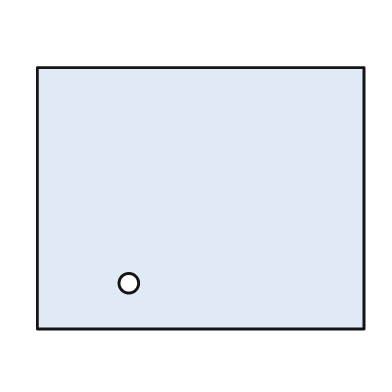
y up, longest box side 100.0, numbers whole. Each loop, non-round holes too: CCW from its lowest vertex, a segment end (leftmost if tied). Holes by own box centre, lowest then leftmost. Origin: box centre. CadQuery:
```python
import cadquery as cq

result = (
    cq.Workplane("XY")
    .moveTo(-50.0, -40.0)
    .lineTo(50.0, -40.0)
    .lineTo(50.0, 40.0)
    .lineTo(-50.0, 40.0)
    .close()
    .moveTo(-22.0, -26.0)
    .circle(3.0)
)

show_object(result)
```